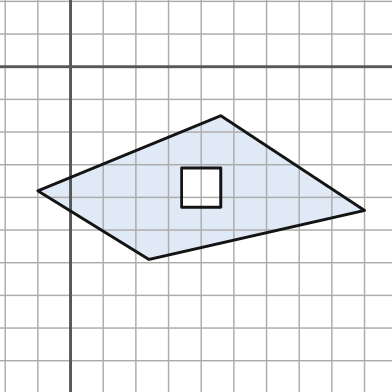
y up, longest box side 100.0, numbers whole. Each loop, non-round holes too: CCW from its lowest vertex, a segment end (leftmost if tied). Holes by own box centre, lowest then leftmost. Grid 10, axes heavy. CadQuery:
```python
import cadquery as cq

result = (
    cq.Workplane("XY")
    .moveTo(24.0, -59.0)
    .lineTo(90.0, -44.0)
    .lineTo(46.0, -15.0)
    .lineTo(-10.0, -38.0)
    .close()
    .moveTo(34.0, -43.0)
    .lineTo(46.0, -43.0)
    .lineTo(46.0, -31.0)
    .lineTo(34.0, -31.0)
    .close()
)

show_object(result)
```